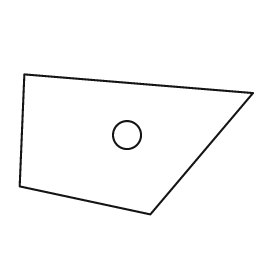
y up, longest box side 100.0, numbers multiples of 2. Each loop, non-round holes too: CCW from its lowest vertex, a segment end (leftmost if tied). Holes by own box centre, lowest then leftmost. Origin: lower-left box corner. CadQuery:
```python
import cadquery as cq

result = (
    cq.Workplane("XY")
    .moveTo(56.0, 0.0)
    .lineTo(100.0, 52.0)
    .lineTo(2.0, 60.0)
    .lineTo(0.0, 12.0)
    .close()
    .moveTo(46.0, 34.0)
    .circle(6.0)
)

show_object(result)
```